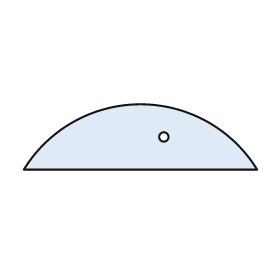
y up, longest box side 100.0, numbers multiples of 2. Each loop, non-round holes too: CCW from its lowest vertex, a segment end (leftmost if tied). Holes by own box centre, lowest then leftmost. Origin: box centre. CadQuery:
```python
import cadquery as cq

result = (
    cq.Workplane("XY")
    .moveTo(-50.0, -14.0)
    .lineTo(50.0, -14.0)
    .threePointArc((0.0, 14.0), (-50.0, -14.0))
    .close()
    .moveTo(10.0, 0.0)
    .circle(2.0)
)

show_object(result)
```